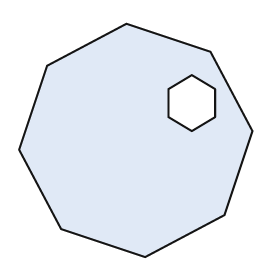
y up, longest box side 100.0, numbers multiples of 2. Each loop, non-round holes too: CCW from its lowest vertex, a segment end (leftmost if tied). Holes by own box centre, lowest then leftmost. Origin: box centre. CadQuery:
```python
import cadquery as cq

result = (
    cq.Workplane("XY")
    .moveTo(4.0, -50.0)
    .lineTo(38.0, -32.0)
    .lineTo(50.0, 4.0)
    .lineTo(32.0, 38.0)
    .lineTo(-4.0, 50.0)
    .lineTo(-38.0, 32.0)
    .lineTo(-50.0, -4.0)
    .lineTo(-32.0, -38.0)
    .close()
    .moveTo(24.0, 4.0)
    .lineTo(34.0, 10.0)
    .lineTo(34.0, 22.0)
    .lineTo(24.0, 28.0)
    .lineTo(14.0, 22.0)
    .lineTo(14.0, 10.0)
    .close()
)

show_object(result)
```